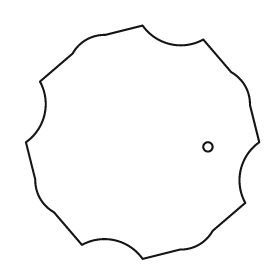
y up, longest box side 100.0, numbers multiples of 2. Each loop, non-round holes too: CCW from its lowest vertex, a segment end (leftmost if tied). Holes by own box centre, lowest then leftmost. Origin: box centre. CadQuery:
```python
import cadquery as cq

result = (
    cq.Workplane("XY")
    .moveTo(0.0, -50.0)
    .lineTo(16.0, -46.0)
    .threePointArc((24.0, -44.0), (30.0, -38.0))
    .lineTo(44.0, -26.0)
    .threePointArc((42.0, -12.0), (50.0, 0.0))
    .lineTo(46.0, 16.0)
    .threePointArc((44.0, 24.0), (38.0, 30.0))
    .lineTo(26.0, 44.0)
    .threePointArc((12.0, 42.0), (0.0, 50.0))
    .lineTo(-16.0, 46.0)
    .threePointArc((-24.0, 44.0), (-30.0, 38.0))
    .lineTo(-44.0, 26.0)
    .threePointArc((-42.0, 12.0), (-50.0, 0.0))
    .lineTo(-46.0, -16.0)
    .threePointArc((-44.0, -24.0), (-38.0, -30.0))
    .lineTo(-26.0, -44.0)
    .threePointArc((-12.0, -42.0), (0.0, -50.0))
    .close()
    .moveTo(28.0, -2.0)
    .circle(2.0)
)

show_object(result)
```